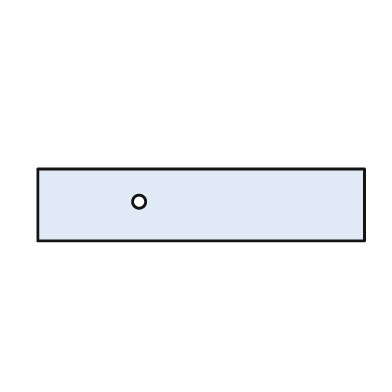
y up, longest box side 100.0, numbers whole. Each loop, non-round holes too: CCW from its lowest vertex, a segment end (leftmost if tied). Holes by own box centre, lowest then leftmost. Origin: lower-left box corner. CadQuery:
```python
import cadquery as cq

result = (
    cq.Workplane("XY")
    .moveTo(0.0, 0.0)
    .lineTo(100.0, 0.0)
    .lineTo(100.0, 22.0)
    .lineTo(0.0, 22.0)
    .close()
    .moveTo(31.0, 12.0)
    .circle(2.0)
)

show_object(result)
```